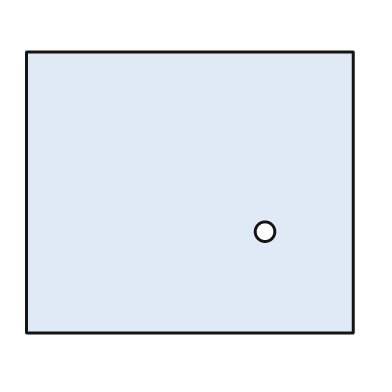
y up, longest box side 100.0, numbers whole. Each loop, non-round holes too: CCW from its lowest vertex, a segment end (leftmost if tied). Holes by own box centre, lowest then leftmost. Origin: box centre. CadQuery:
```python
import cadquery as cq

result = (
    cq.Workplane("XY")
    .moveTo(-50.0, -43.0)
    .lineTo(50.0, -43.0)
    .lineTo(50.0, 43.0)
    .lineTo(-50.0, 43.0)
    .close()
    .moveTo(23.0, -12.0)
    .circle(3.0)
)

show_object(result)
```